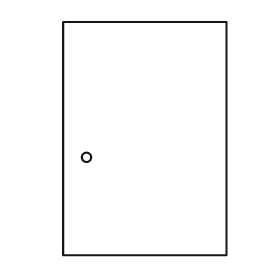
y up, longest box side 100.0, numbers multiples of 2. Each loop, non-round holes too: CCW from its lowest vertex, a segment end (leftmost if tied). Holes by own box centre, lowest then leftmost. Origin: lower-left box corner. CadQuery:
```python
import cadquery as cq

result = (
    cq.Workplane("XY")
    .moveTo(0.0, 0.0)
    .lineTo(70.0, 0.0)
    .lineTo(70.0, 100.0)
    .lineTo(0.0, 100.0)
    .close()
    .moveTo(10.0, 42.0)
    .circle(2.0)
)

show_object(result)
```